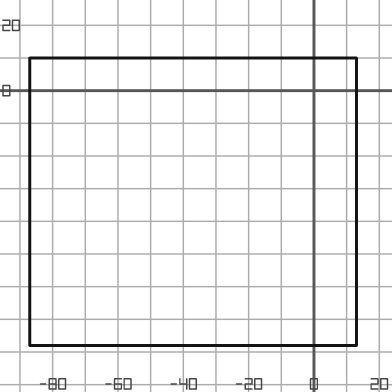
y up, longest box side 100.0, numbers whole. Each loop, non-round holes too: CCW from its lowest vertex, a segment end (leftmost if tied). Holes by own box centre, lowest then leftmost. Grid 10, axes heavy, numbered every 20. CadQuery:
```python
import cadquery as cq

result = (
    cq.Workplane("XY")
    .moveTo(-87.0, -78.0)
    .lineTo(13.0, -78.0)
    .lineTo(13.0, 10.0)
    .lineTo(-87.0, 10.0)
    .close()
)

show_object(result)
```